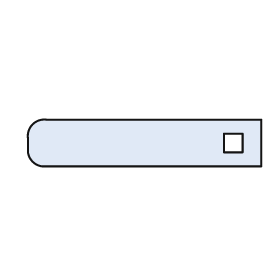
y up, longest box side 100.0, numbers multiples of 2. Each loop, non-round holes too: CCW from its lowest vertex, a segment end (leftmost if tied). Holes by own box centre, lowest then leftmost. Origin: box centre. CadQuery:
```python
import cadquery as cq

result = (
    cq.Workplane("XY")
    .moveTo(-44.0, -10.0)
    .lineTo(50.0, -10.0)
    .lineTo(50.0, 10.0)
    .lineTo(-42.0, 10.0)
    .threePointArc((-48.0, 8.0), (-50.0, 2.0))
    .lineTo(-50.0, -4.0)
    .threePointArc((-48.0, -8.0), (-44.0, -10.0))
    .close()
    .moveTo(34.0, -4.0)
    .lineTo(42.0, -4.0)
    .lineTo(42.0, 4.0)
    .lineTo(34.0, 4.0)
    .close()
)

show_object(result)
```